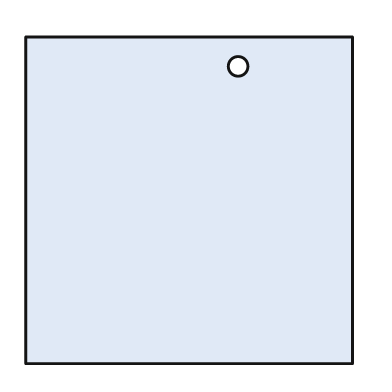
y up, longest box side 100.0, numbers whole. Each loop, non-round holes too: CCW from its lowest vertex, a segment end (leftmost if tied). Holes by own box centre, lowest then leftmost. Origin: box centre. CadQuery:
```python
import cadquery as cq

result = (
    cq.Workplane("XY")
    .moveTo(-50.0, -50.0)
    .lineTo(50.0, -50.0)
    .lineTo(50.0, 50.0)
    .lineTo(-50.0, 50.0)
    .close()
    .moveTo(15.0, 41.0)
    .circle(3.0)
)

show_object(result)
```